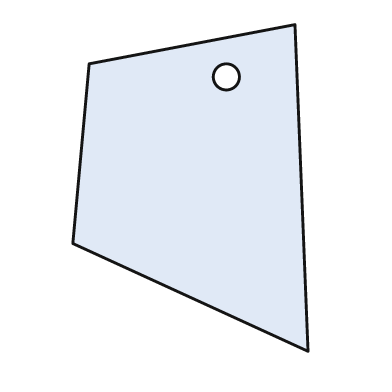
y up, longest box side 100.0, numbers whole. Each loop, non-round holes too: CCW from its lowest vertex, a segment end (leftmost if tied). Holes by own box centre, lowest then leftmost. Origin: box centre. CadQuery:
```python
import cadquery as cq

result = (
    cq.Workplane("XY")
    .moveTo(36.0, -50.0)
    .lineTo(32.0, 50.0)
    .lineTo(-31.0, 38.0)
    .lineTo(-36.0, -17.0)
    .close()
    .moveTo(11.0, 34.0)
    .circle(4.0)
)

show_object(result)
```